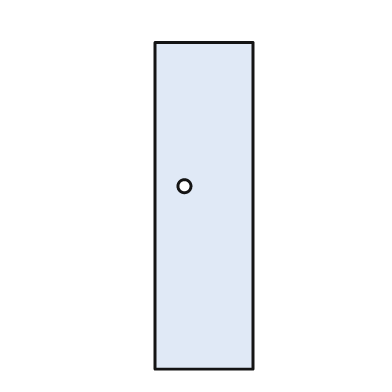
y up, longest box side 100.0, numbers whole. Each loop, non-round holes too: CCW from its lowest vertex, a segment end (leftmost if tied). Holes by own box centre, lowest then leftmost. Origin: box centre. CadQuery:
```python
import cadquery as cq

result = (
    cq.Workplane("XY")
    .moveTo(-15.0, -50.0)
    .lineTo(15.0, -50.0)
    .lineTo(15.0, 50.0)
    .lineTo(-15.0, 50.0)
    .close()
    .moveTo(-6.0, 6.0)
    .circle(2.0)
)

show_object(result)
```